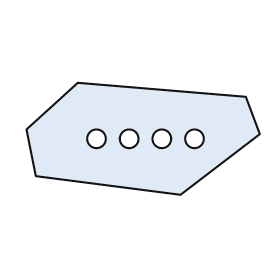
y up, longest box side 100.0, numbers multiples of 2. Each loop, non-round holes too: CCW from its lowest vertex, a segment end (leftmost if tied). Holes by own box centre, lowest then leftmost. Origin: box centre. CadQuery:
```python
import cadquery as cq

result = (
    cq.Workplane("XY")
    .moveTo(16.0, -24.0)
    .lineTo(50.0, 2.0)
    .lineTo(44.0, 18.0)
    .lineTo(-28.0, 24.0)
    .lineTo(-50.0, 4.0)
    .lineTo(-46.0, -16.0)
    .close()
    .moveTo(-20.0, 0.0)
    .circle(4.0)
    .moveTo(-6.0, 0.0)
    .circle(4.0)
    .moveTo(8.0, 0.0)
    .circle(4.0)
    .moveTo(22.0, 0.0)
    .circle(4.0)
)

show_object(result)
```